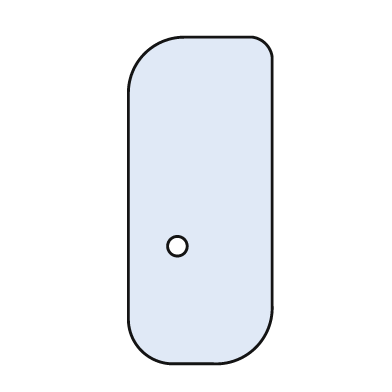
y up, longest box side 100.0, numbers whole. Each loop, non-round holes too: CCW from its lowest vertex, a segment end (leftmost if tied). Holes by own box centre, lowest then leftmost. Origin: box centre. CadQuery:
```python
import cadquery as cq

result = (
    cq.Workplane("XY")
    .moveTo(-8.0, -50.0)
    .lineTo(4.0, -50.0)
    .threePointArc((17.0, -45.0), (22.0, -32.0))
    .lineTo(22.0, 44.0)
    .threePointArc((20.0, 48.0), (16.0, 50.0))
    .lineTo(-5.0, 50.0)
    .threePointArc((-17.0, 45.0), (-22.0, 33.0))
    .lineTo(-22.0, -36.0)
    .threePointArc((-18.0, -46.0), (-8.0, -50.0))
    .close()
    .moveTo(-7.0, -14.0)
    .circle(3.0)
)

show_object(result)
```